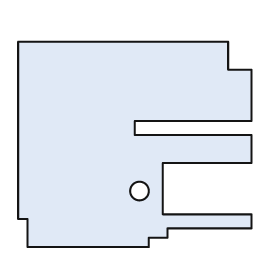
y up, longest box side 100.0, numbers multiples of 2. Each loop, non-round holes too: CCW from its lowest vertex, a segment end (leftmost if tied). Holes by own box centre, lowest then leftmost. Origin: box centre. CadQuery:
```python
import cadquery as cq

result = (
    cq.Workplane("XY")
    .moveTo(-46.0, -44.0)
    .lineTo(6.0, -44.0)
    .lineTo(6.0, -40.0)
    .lineTo(14.0, -40.0)
    .lineTo(14.0, -36.0)
    .lineTo(50.0, -36.0)
    .lineTo(50.0, -30.0)
    .lineTo(12.0, -30.0)
    .lineTo(12.0, -8.0)
    .lineTo(50.0, -8.0)
    .lineTo(50.0, 4.0)
    .lineTo(0.0, 4.0)
    .lineTo(0.0, 10.0)
    .lineTo(50.0, 10.0)
    .lineTo(50.0, 32.0)
    .lineTo(40.0, 32.0)
    .lineTo(40.0, 44.0)
    .lineTo(-50.0, 44.0)
    .lineTo(-50.0, -32.0)
    .lineTo(-46.0, -32.0)
    .close()
    .moveTo(2.0, -20.0)
    .circle(4.0)
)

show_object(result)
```